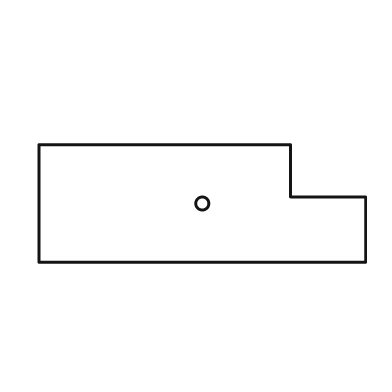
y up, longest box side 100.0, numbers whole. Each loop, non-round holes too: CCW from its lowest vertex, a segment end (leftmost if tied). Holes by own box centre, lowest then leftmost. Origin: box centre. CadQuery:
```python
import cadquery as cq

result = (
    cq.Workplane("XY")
    .moveTo(-50.0, -18.0)
    .lineTo(50.0, -18.0)
    .lineTo(50.0, 2.0)
    .lineTo(27.0, 2.0)
    .lineTo(27.0, 18.0)
    .lineTo(-50.0, 18.0)
    .close()
    .moveTo(0.0, 0.0)
    .circle(2.0)
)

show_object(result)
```